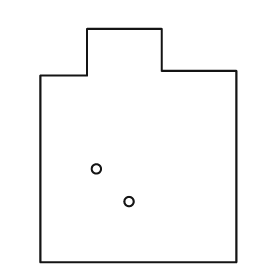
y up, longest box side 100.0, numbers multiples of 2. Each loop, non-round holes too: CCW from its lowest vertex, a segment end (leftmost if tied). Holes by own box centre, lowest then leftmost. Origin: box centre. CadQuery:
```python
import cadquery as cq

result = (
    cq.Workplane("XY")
    .moveTo(-42.0, -50.0)
    .lineTo(42.0, -50.0)
    .lineTo(42.0, 32.0)
    .lineTo(10.0, 32.0)
    .lineTo(10.0, 50.0)
    .lineTo(-22.0, 50.0)
    .lineTo(-22.0, 30.0)
    .lineTo(-42.0, 30.0)
    .close()
    .moveTo(-4.0, -24.0)
    .circle(2.0)
    .moveTo(-18.0, -10.0)
    .circle(2.0)
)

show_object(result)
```